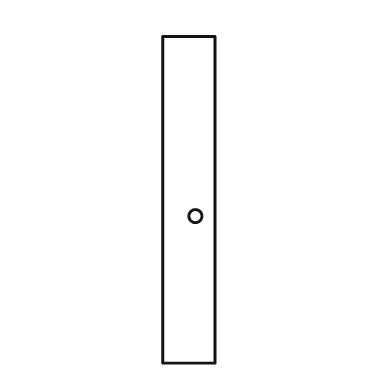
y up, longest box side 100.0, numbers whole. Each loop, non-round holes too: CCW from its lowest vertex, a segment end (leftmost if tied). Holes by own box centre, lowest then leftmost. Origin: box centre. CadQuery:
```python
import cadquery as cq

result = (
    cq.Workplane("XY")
    .moveTo(-8.0, -50.0)
    .lineTo(8.0, -50.0)
    .lineTo(8.0, 50.0)
    .lineTo(-8.0, 50.0)
    .close()
    .moveTo(2.0, -5.0)
    .circle(2.0)
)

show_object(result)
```